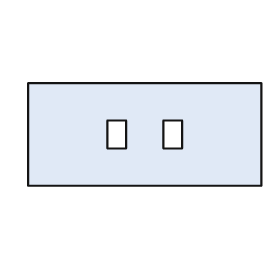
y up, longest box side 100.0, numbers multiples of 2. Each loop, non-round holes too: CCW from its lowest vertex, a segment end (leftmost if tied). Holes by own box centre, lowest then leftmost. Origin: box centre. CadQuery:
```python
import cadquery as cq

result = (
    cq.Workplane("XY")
    .moveTo(-50.0, -22.0)
    .lineTo(50.0, -22.0)
    .lineTo(50.0, 22.0)
    .lineTo(-50.0, 22.0)
    .close()
    .moveTo(-16.0, -6.0)
    .lineTo(-8.0, -6.0)
    .lineTo(-8.0, 6.0)
    .lineTo(-16.0, 6.0)
    .close()
    .moveTo(8.0, -6.0)
    .lineTo(16.0, -6.0)
    .lineTo(16.0, 6.0)
    .lineTo(8.0, 6.0)
    .close()
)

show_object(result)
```